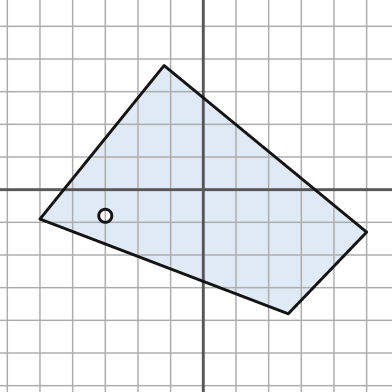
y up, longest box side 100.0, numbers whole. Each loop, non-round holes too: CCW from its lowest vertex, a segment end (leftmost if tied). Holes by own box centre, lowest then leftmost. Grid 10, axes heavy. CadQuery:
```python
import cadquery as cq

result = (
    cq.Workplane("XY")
    .moveTo(26.0, -38.0)
    .lineTo(50.0, -13.0)
    .lineTo(-12.0, 38.0)
    .lineTo(-50.0, -9.0)
    .close()
    .moveTo(-30.0, -8.0)
    .circle(2.0)
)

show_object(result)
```